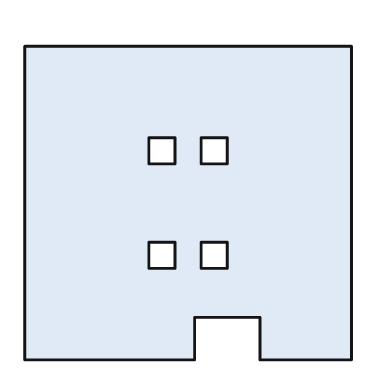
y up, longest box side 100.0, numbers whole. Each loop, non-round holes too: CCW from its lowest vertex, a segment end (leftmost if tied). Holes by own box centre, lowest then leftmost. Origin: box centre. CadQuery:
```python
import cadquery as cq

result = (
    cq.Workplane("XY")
    .moveTo(-50.0, -48.0)
    .lineTo(2.0, -48.0)
    .lineTo(2.0, -35.0)
    .lineTo(22.0, -35.0)
    .lineTo(22.0, -48.0)
    .lineTo(50.0, -48.0)
    .lineTo(50.0, 48.0)
    .lineTo(-50.0, 48.0)
    .close()
    .moveTo(-12.0, -20.0)
    .lineTo(-4.0, -20.0)
    .lineTo(-4.0, -12.0)
    .lineTo(-12.0, -12.0)
    .close()
    .moveTo(4.0, -20.0)
    .lineTo(12.0, -20.0)
    .lineTo(12.0, -12.0)
    .lineTo(4.0, -12.0)
    .close()
    .moveTo(-12.0, 12.0)
    .lineTo(-4.0, 12.0)
    .lineTo(-4.0, 20.0)
    .lineTo(-12.0, 20.0)
    .close()
    .moveTo(4.0, 12.0)
    .lineTo(12.0, 12.0)
    .lineTo(12.0, 20.0)
    .lineTo(4.0, 20.0)
    .close()
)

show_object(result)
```